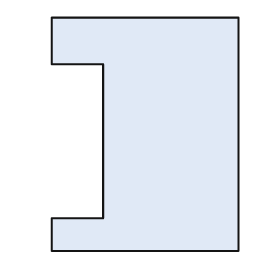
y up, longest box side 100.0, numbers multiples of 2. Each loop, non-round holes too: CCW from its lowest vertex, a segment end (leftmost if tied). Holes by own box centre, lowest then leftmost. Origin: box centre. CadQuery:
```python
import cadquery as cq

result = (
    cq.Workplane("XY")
    .moveTo(-40.0, -50.0)
    .lineTo(40.0, -50.0)
    .lineTo(40.0, 50.0)
    .lineTo(-40.0, 50.0)
    .lineTo(-40.0, 30.0)
    .lineTo(-18.0, 30.0)
    .lineTo(-18.0, -36.0)
    .lineTo(-40.0, -36.0)
    .close()
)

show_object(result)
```